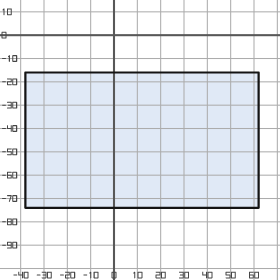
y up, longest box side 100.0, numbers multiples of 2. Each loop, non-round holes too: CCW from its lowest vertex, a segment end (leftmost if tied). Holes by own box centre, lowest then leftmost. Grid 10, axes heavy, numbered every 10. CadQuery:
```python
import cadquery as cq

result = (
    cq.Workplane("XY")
    .moveTo(-38.0, -74.0)
    .lineTo(62.0, -74.0)
    .lineTo(62.0, -16.0)
    .lineTo(-38.0, -16.0)
    .close()
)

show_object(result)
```